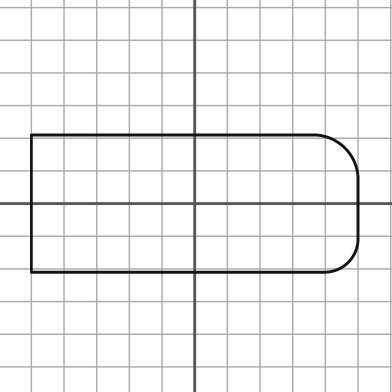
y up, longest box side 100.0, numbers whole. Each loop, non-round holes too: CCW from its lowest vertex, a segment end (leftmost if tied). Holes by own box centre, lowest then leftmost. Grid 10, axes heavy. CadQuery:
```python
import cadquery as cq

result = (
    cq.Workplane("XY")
    .moveTo(-50.0, -21.0)
    .lineTo(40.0, -21.0)
    .threePointArc((47.0, -18.0), (50.0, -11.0))
    .lineTo(50.0, 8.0)
    .threePointArc((46.0, 17.0), (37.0, 21.0))
    .lineTo(-50.0, 21.0)
    .close()
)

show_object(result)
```